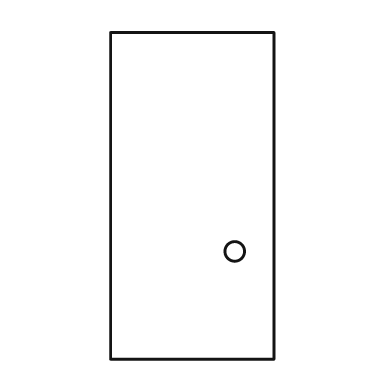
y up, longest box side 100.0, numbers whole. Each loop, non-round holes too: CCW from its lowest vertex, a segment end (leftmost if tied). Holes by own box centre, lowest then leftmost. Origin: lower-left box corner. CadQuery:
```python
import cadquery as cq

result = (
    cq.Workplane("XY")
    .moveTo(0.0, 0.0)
    .lineTo(50.0, 0.0)
    .lineTo(50.0, 100.0)
    .lineTo(0.0, 100.0)
    .close()
    .moveTo(38.0, 33.0)
    .circle(3.0)
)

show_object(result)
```